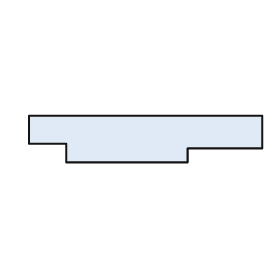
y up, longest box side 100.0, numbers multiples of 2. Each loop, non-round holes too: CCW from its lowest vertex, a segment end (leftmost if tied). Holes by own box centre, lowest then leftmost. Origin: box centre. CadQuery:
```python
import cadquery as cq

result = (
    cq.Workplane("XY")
    .moveTo(-34.0, -10.0)
    .lineTo(18.0, -10.0)
    .lineTo(18.0, -4.0)
    .lineTo(50.0, -4.0)
    .lineTo(50.0, 10.0)
    .lineTo(-50.0, 10.0)
    .lineTo(-50.0, -2.0)
    .lineTo(-34.0, -2.0)
    .close()
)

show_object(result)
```